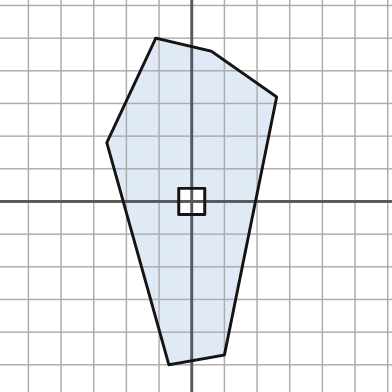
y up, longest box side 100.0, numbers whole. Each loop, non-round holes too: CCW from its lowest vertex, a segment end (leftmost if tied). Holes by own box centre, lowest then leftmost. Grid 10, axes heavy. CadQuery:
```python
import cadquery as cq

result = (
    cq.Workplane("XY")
    .moveTo(-7.0, -50.0)
    .lineTo(10.0, -47.0)
    .lineTo(26.0, 32.0)
    .lineTo(6.0, 46.0)
    .lineTo(-11.0, 50.0)
    .lineTo(-26.0, 18.0)
    .close()
    .moveTo(-4.0, -4.0)
    .lineTo(4.0, -4.0)
    .lineTo(4.0, 4.0)
    .lineTo(-4.0, 4.0)
    .close()
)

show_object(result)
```